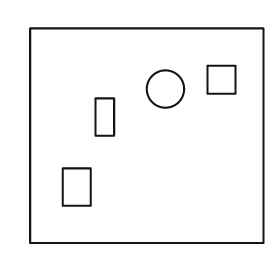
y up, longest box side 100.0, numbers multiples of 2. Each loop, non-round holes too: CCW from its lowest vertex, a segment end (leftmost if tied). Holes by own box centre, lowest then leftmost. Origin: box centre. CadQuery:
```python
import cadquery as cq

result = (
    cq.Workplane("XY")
    .moveTo(-50.0, -46.0)
    .lineTo(50.0, -46.0)
    .lineTo(50.0, 46.0)
    .lineTo(-50.0, 46.0)
    .close()
    .moveTo(-36.0, -30.0)
    .lineTo(-24.0, -30.0)
    .lineTo(-24.0, -14.0)
    .lineTo(-36.0, -14.0)
    .close()
    .moveTo(-22.0, 0.0)
    .lineTo(-14.0, 0.0)
    .lineTo(-14.0, 16.0)
    .lineTo(-22.0, 16.0)
    .close()
    .moveTo(8.0, 20.0)
    .circle(8.0)
    .moveTo(26.0, 18.0)
    .lineTo(38.0, 18.0)
    .lineTo(38.0, 30.0)
    .lineTo(26.0, 30.0)
    .close()
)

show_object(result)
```